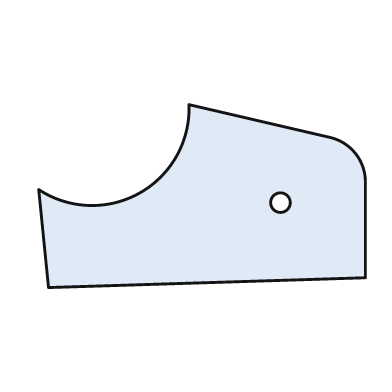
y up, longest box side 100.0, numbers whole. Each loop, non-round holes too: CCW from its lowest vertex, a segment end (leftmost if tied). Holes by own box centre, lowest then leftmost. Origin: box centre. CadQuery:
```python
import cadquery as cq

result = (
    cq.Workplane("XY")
    .moveTo(-47.0, -28.0)
    .lineTo(50.0, -25.0)
    .lineTo(50.0, 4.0)
    .threePointArc((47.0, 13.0), (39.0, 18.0))
    .lineTo(-4.0, 28.0)
    .threePointArc((-19.0, 1.0), (-50.0, 2.0))
    .close()
    .moveTo(24.0, -2.0)
    .circle(3.0)
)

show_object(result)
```